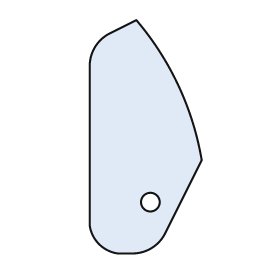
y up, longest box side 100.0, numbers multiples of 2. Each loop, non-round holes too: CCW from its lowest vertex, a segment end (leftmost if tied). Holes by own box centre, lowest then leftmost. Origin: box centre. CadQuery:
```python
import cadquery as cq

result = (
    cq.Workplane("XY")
    .moveTo(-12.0, -50.0)
    .lineTo(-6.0, -50.0)
    .threePointArc((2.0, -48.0), (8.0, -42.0))
    .lineTo(24.0, -10.0)
    .threePointArc((14.0, 22.0), (-4.0, 50.0))
    .lineTo(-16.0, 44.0)
    .threePointArc((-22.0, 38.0), (-24.0, 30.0))
    .lineTo(-24.0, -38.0)
    .threePointArc((-20.0, -46.0), (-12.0, -50.0))
    .close()
    .moveTo(2.0, -28.0)
    .circle(4.0)
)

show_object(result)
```